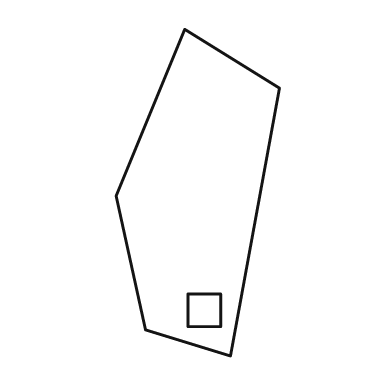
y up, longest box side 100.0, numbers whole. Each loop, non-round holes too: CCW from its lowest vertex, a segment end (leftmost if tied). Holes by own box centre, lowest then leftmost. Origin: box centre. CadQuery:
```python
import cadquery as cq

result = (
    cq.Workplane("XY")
    .moveTo(10.0, -50.0)
    .lineTo(25.0, 32.0)
    .lineTo(-4.0, 50.0)
    .lineTo(-25.0, -1.0)
    .lineTo(-16.0, -42.0)
    .close()
    .moveTo(-3.0, -41.0)
    .lineTo(7.0, -41.0)
    .lineTo(7.0, -31.0)
    .lineTo(-3.0, -31.0)
    .close()
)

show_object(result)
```